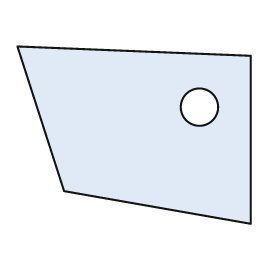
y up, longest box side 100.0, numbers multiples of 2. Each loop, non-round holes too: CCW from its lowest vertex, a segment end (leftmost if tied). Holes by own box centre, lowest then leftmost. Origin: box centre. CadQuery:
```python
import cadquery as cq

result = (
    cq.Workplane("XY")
    .moveTo(50.0, -38.0)
    .lineTo(50.0, 34.0)
    .lineTo(-50.0, 38.0)
    .lineTo(-30.0, -24.0)
    .close()
    .moveTo(28.0, 12.0)
    .circle(8.0)
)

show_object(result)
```